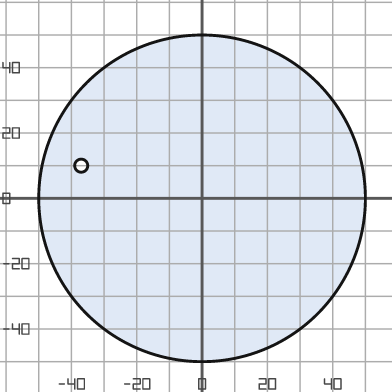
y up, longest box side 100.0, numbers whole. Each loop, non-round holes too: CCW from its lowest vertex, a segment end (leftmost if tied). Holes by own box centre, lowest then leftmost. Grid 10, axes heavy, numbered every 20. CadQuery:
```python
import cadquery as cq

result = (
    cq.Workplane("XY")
    .moveTo(0.0, 0.0)
    .circle(50.0)
    .moveTo(-37.0, 10.0)
    .circle(2.0)
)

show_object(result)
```